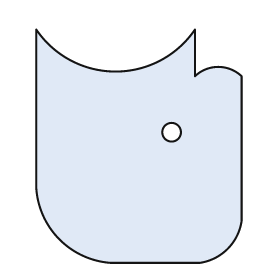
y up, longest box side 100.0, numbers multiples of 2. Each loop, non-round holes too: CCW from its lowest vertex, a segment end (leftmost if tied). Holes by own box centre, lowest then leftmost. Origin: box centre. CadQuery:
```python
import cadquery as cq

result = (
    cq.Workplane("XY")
    .moveTo(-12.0, -50.0)
    .lineTo(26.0, -50.0)
    .threePointArc((38.0, -44.0), (44.0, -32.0))
    .lineTo(44.0, 30.0)
    .threePointArc((34.0, 34.0), (24.0, 30.0))
    .lineTo(24.0, 50.0)
    .threePointArc((-10.0, 32.0), (-44.0, 50.0))
    .lineTo(-44.0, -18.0)
    .threePointArc((-34.0, -40.0), (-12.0, -50.0))
    .close()
    .moveTo(14.0, 6.0)
    .circle(4.0)
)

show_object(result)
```